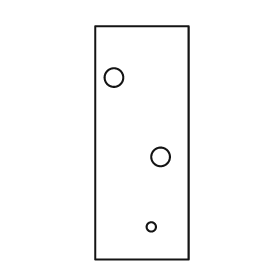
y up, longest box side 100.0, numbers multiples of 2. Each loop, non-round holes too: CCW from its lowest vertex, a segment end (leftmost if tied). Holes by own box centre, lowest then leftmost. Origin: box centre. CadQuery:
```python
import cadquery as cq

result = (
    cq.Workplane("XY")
    .moveTo(-20.0, -50.0)
    .lineTo(20.0, -50.0)
    .lineTo(20.0, 50.0)
    .lineTo(-20.0, 50.0)
    .close()
    .moveTo(4.0, -36.0)
    .circle(2.0)
    .moveTo(8.0, -6.0)
    .circle(4.0)
    .moveTo(-12.0, 28.0)
    .circle(4.0)
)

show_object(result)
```